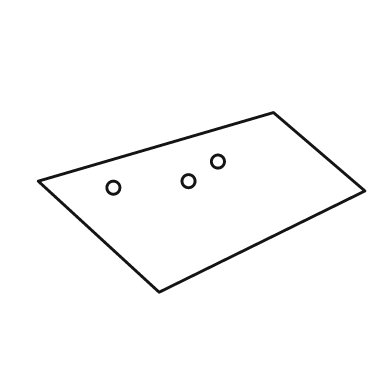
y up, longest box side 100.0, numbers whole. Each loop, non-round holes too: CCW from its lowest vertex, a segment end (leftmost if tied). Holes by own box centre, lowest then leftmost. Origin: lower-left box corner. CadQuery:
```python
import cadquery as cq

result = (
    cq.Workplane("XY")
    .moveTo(37.0, 0.0)
    .lineTo(100.0, 31.0)
    .lineTo(72.0, 55.0)
    .lineTo(0.0, 34.0)
    .close()
    .moveTo(23.0, 32.0)
    .circle(2.0)
    .moveTo(46.0, 34.0)
    .circle(2.0)
    .moveTo(55.0, 40.0)
    .circle(2.0)
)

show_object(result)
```